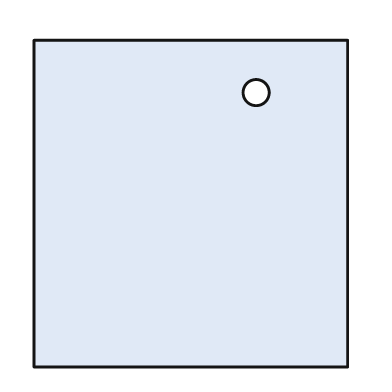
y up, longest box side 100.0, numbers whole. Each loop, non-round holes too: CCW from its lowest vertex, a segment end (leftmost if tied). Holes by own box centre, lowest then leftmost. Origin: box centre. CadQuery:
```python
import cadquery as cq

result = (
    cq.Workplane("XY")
    .moveTo(-48.0, -50.0)
    .lineTo(48.0, -50.0)
    .lineTo(48.0, 50.0)
    .lineTo(-48.0, 50.0)
    .close()
    .moveTo(20.0, 34.0)
    .circle(4.0)
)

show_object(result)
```